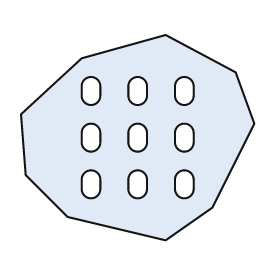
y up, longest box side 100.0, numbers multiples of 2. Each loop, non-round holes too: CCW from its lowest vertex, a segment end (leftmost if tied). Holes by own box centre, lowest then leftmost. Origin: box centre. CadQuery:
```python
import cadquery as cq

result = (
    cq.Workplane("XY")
    .moveTo(12.0, -44.0)
    .lineTo(32.0, -30.0)
    .lineTo(50.0, 6.0)
    .lineTo(42.0, 28.0)
    .lineTo(12.0, 44.0)
    .lineTo(-24.0, 34.0)
    .lineTo(-50.0, 10.0)
    .lineTo(-48.0, -16.0)
    .lineTo(-30.0, -34.0)
    .close()
    .moveTo(-24.0, -22.0)
    .threePointArc((-20.0, -26.0), (-16.0, -22.0))
    .lineTo(-16.0, -18.0)
    .threePointArc((-20.0, -14.0), (-24.0, -18.0))
    .close()
    .moveTo(-4.0, -22.0)
    .threePointArc((0.0, -26.0), (4.0, -22.0))
    .lineTo(4.0, -18.0)
    .threePointArc((0.0, -14.0), (-4.0, -18.0))
    .close()
    .moveTo(16.0, -22.0)
    .threePointArc((20.0, -26.0), (24.0, -22.0))
    .lineTo(24.0, -18.0)
    .threePointArc((20.0, -14.0), (16.0, -18.0))
    .close()
    .moveTo(-24.0, -2.0)
    .threePointArc((-20.0, -6.0), (-16.0, -2.0))
    .lineTo(-16.0, 2.0)
    .threePointArc((-20.0, 6.0), (-24.0, 2.0))
    .close()
    .moveTo(-4.0, -2.0)
    .threePointArc((0.0, -6.0), (4.0, -2.0))
    .lineTo(4.0, 2.0)
    .threePointArc((0.0, 6.0), (-4.0, 2.0))
    .close()
    .moveTo(16.0, -2.0)
    .threePointArc((20.0, -6.0), (24.0, -2.0))
    .lineTo(24.0, 2.0)
    .threePointArc((20.0, 6.0), (16.0, 2.0))
    .close()
    .moveTo(-24.0, 18.0)
    .threePointArc((-20.0, 14.0), (-16.0, 18.0))
    .lineTo(-16.0, 22.0)
    .threePointArc((-20.0, 26.0), (-24.0, 22.0))
    .close()
    .moveTo(-4.0, 18.0)
    .threePointArc((0.0, 14.0), (4.0, 18.0))
    .lineTo(4.0, 22.0)
    .threePointArc((0.0, 26.0), (-4.0, 22.0))
    .close()
    .moveTo(16.0, 18.0)
    .threePointArc((20.0, 14.0), (24.0, 18.0))
    .lineTo(24.0, 22.0)
    .threePointArc((20.0, 26.0), (16.0, 22.0))
    .close()
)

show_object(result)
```